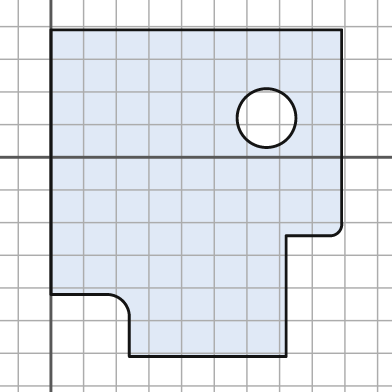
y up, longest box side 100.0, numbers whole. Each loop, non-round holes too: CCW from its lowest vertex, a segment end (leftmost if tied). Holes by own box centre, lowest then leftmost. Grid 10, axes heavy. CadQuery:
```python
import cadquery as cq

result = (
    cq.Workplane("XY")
    .moveTo(24.0, -61.0)
    .lineTo(72.0, -61.0)
    .lineTo(72.0, -24.0)
    .lineTo(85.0, -24.0)
    .threePointArc((88.0, -23.0), (89.0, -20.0))
    .lineTo(89.0, 39.0)
    .lineTo(0.0, 39.0)
    .lineTo(0.0, -42.0)
    .lineTo(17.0, -42.0)
    .threePointArc((22.0, -44.0), (24.0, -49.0))
    .close()
    .moveTo(66.0, 12.0)
    .circle(9.0)
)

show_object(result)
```